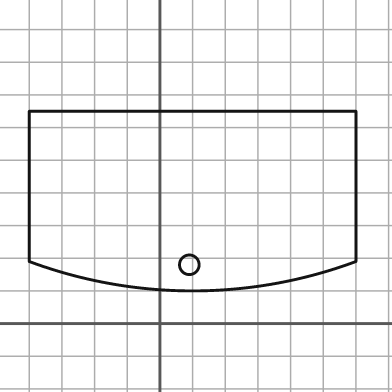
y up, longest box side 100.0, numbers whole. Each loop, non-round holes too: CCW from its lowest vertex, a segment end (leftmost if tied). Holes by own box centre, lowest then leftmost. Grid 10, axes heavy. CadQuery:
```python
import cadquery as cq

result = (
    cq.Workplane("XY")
    .moveTo(-40.0, 19.0)
    .threePointArc((10.0, 10.0), (60.0, 19.0))
    .lineTo(60.0, 65.0)
    .lineTo(-40.0, 65.0)
    .close()
    .moveTo(9.0, 18.0)
    .circle(3.0)
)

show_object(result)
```